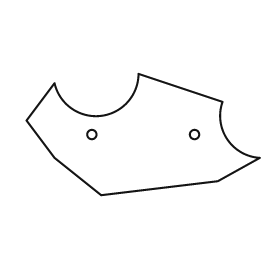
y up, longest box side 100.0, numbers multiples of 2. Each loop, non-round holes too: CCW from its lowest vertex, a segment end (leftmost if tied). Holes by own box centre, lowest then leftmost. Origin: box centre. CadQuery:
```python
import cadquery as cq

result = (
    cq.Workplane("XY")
    .moveTo(-18.0, -26.0)
    .lineTo(32.0, -20.0)
    .lineTo(50.0, -10.0)
    .threePointArc((36.0, -2.0), (34.0, 14.0))
    .lineTo(-2.0, 26.0)
    .threePointArc((-18.0, 8.0), (-38.0, 22.0))
    .lineTo(-50.0, 6.0)
    .lineTo(-38.0, -10.0)
    .close()
    .moveTo(-22.0, 0.0)
    .circle(2.0)
    .moveTo(22.0, 0.0)
    .circle(2.0)
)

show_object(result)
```